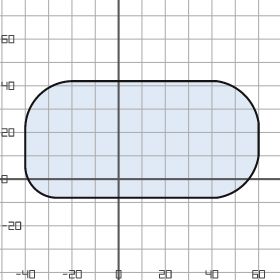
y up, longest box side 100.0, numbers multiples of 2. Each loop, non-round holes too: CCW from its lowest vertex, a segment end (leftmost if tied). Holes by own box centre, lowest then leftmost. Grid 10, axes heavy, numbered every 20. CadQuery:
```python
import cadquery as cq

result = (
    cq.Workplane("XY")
    .moveTo(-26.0, -8.0)
    .lineTo(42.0, -8.0)
    .threePointArc((54.0, -2.0), (60.0, 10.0))
    .lineTo(60.0, 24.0)
    .threePointArc((54.0, 36.0), (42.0, 42.0))
    .lineTo(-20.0, 42.0)
    .threePointArc((-34.0, 36.0), (-40.0, 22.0))
    .lineTo(-40.0, 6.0)
    .threePointArc((-36.0, -4.0), (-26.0, -8.0))
    .close()
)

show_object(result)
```